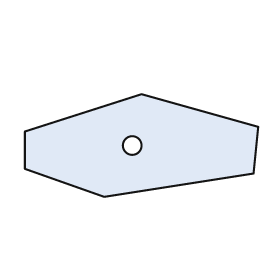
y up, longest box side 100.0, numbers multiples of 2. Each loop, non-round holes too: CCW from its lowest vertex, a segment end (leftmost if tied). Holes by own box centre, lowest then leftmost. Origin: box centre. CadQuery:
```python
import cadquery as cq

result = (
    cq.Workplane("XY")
    .moveTo(-16.0, -22.0)
    .lineTo(48.0, -12.0)
    .lineTo(50.0, 8.0)
    .lineTo(0.0, 22.0)
    .lineTo(-50.0, 6.0)
    .lineTo(-50.0, -10.0)
    .close()
    .moveTo(-4.0, 0.0)
    .circle(4.0)
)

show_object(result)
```